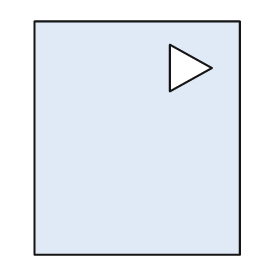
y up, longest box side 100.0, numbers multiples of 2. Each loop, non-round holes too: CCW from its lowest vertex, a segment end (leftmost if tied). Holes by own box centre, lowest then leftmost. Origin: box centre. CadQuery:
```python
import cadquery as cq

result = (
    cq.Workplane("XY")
    .moveTo(-44.0, -50.0)
    .lineTo(44.0, -50.0)
    .lineTo(44.0, 50.0)
    .lineTo(-44.0, 50.0)
    .close()
    .moveTo(14.0, 20.0)
    .lineTo(32.0, 30.0)
    .lineTo(14.0, 40.0)
    .close()
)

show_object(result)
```